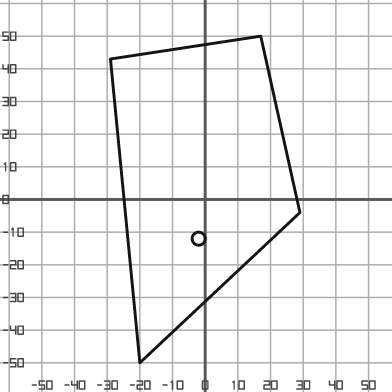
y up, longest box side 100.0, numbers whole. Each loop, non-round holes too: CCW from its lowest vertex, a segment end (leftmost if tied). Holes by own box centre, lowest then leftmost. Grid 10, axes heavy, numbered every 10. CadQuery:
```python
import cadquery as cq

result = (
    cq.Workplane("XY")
    .moveTo(-20.0, -50.0)
    .lineTo(29.0, -4.0)
    .lineTo(17.0, 50.0)
    .lineTo(-29.0, 43.0)
    .close()
    .moveTo(-2.0, -12.0)
    .circle(2.0)
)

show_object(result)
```